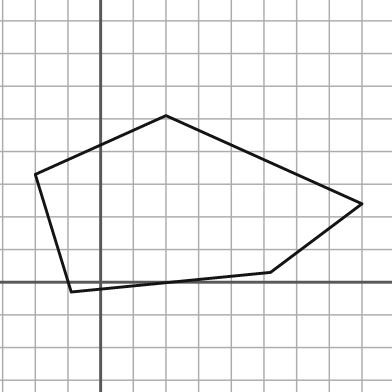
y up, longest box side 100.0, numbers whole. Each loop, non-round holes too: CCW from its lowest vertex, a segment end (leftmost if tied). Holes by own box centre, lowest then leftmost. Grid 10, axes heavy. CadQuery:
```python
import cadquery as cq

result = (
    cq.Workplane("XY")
    .moveTo(-9.0, -3.0)
    .lineTo(52.0, 3.0)
    .lineTo(80.0, 24.0)
    .lineTo(20.0, 51.0)
    .lineTo(-20.0, 33.0)
    .close()
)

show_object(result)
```